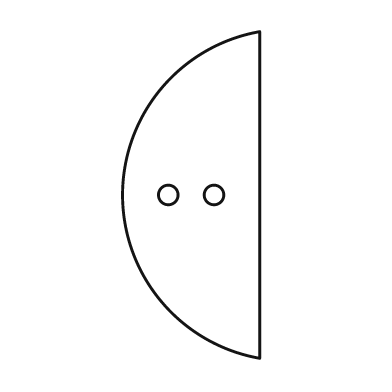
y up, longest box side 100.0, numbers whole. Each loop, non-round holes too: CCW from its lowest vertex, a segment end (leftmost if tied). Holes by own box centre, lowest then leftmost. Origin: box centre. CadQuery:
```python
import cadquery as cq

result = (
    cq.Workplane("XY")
    .moveTo(21.0, -50.0)
    .lineTo(21.0, 50.0)
    .threePointArc((-21.0, 0.0), (21.0, -50.0))
    .close()
    .moveTo(-7.0, 0.0)
    .circle(3.0)
    .moveTo(7.0, 0.0)
    .circle(3.0)
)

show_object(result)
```